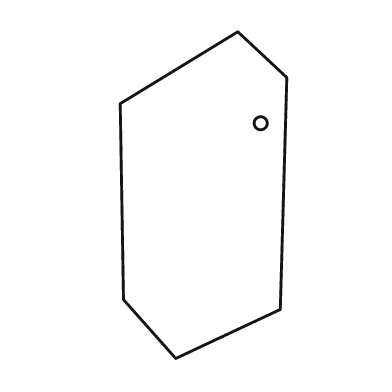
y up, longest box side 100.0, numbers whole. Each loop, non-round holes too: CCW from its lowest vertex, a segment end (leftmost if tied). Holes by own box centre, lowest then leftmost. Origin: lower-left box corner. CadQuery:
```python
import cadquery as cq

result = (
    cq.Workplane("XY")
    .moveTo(17.0, 0.0)
    .lineTo(49.0, 15.0)
    .lineTo(51.0, 86.0)
    .lineTo(36.0, 100.0)
    .lineTo(0.0, 78.0)
    .lineTo(1.0, 18.0)
    .close()
    .moveTo(43.0, 72.0)
    .circle(2.0)
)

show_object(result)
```